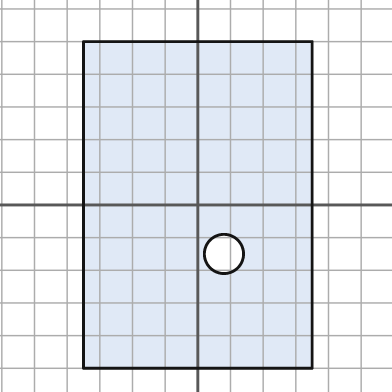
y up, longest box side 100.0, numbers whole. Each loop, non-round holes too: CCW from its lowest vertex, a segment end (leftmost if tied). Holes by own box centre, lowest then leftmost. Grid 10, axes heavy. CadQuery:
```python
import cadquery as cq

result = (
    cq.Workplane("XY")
    .moveTo(-35.0, -50.0)
    .lineTo(35.0, -50.0)
    .lineTo(35.0, 50.0)
    .lineTo(-35.0, 50.0)
    .close()
    .moveTo(8.0, -15.0)
    .circle(6.0)
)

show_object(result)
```